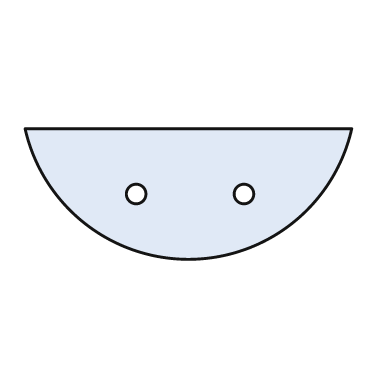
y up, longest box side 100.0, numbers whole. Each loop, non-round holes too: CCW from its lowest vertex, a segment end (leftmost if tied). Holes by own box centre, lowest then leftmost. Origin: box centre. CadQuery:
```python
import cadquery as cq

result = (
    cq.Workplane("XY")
    .moveTo(-50.0, 20.0)
    .threePointArc((0.0, -20.0), (50.0, 20.0))
    .close()
    .moveTo(-16.0, 0.0)
    .circle(3.0)
    .moveTo(17.0, 0.0)
    .circle(3.0)
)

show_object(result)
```